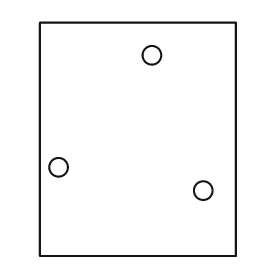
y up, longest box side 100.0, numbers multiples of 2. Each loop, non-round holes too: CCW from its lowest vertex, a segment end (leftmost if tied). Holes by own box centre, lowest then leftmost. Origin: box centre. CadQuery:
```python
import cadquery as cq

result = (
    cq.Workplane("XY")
    .moveTo(-42.0, -50.0)
    .lineTo(42.0, -50.0)
    .lineTo(42.0, 50.0)
    .lineTo(-42.0, 50.0)
    .close()
    .moveTo(28.0, -22.0)
    .circle(4.0)
    .moveTo(-34.0, -12.0)
    .circle(4.0)
    .moveTo(6.0, 36.0)
    .circle(4.0)
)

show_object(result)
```